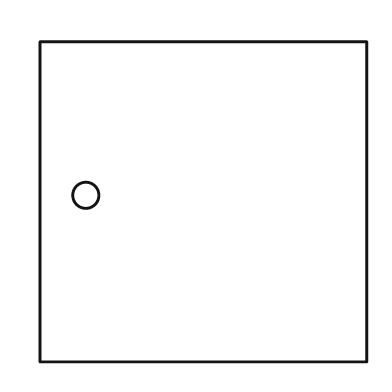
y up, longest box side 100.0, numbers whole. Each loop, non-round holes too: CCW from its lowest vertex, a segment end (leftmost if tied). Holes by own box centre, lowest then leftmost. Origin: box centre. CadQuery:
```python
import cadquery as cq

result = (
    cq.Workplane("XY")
    .moveTo(-50.0, -49.0)
    .lineTo(50.0, -49.0)
    .lineTo(50.0, 49.0)
    .lineTo(-50.0, 49.0)
    .close()
    .moveTo(-36.0, 2.0)
    .circle(4.0)
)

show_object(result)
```